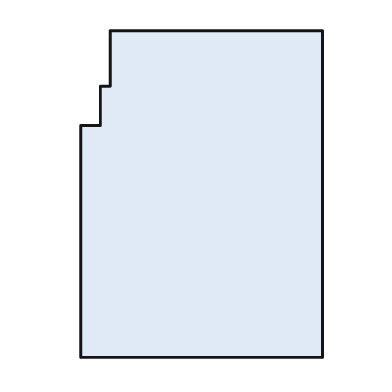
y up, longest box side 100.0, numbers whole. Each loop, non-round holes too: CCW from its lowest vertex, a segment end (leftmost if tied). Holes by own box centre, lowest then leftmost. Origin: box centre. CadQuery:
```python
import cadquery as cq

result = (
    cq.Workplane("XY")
    .moveTo(-37.0, -50.0)
    .lineTo(37.0, -50.0)
    .lineTo(37.0, 50.0)
    .lineTo(-28.0, 50.0)
    .lineTo(-28.0, 33.0)
    .lineTo(-31.0, 33.0)
    .lineTo(-31.0, 21.0)
    .lineTo(-37.0, 21.0)
    .close()
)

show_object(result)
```